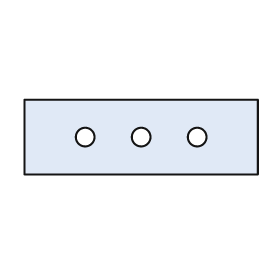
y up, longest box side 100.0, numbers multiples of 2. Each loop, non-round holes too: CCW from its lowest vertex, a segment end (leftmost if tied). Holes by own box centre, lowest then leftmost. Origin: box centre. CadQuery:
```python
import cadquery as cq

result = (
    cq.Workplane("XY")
    .moveTo(-50.0, -16.0)
    .lineTo(50.0, -16.0)
    .lineTo(50.0, 16.0)
    .lineTo(-50.0, 16.0)
    .close()
    .moveTo(-24.0, 0.0)
    .circle(4.0)
    .moveTo(0.0, 0.0)
    .circle(4.0)
    .moveTo(24.0, 0.0)
    .circle(4.0)
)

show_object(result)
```